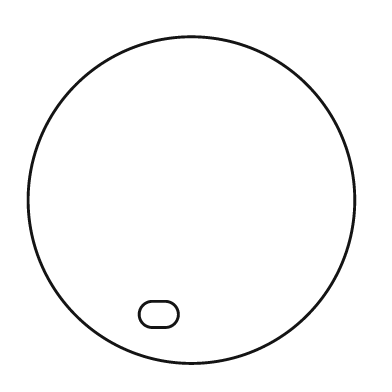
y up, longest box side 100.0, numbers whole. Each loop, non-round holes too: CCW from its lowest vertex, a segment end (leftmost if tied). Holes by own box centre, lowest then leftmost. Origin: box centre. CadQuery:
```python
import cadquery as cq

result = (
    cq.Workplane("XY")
    .moveTo(0.0, 0.0)
    .circle(50.0)
    .moveTo(-12.0, -39.0)
    .lineTo(-8.0, -39.0)
    .threePointArc((-4.0, -35.0), (-8.0, -31.0))
    .lineTo(-12.0, -31.0)
    .threePointArc((-16.0, -35.0), (-12.0, -39.0))
    .close()
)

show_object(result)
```